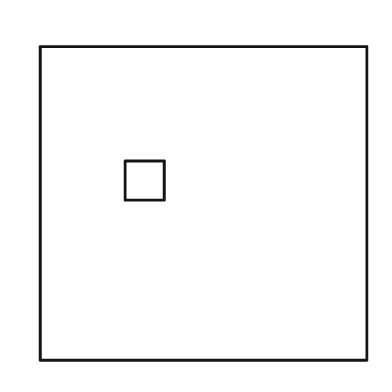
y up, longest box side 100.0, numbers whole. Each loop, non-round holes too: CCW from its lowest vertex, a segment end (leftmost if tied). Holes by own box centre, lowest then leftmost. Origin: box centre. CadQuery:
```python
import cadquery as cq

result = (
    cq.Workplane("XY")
    .moveTo(-50.0, -48.0)
    .lineTo(50.0, -48.0)
    .lineTo(50.0, 48.0)
    .lineTo(-50.0, 48.0)
    .close()
    .moveTo(-24.0, 1.0)
    .lineTo(-12.0, 1.0)
    .lineTo(-12.0, 13.0)
    .lineTo(-24.0, 13.0)
    .close()
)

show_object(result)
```